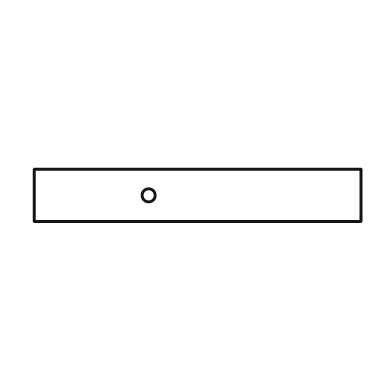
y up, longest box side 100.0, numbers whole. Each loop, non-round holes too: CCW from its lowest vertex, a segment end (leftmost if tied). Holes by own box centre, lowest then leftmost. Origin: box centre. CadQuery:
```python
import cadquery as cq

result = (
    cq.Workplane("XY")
    .moveTo(-50.0, -8.0)
    .lineTo(50.0, -8.0)
    .lineTo(50.0, 8.0)
    .lineTo(-50.0, 8.0)
    .close()
    .moveTo(-15.0, 0.0)
    .circle(2.0)
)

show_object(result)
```